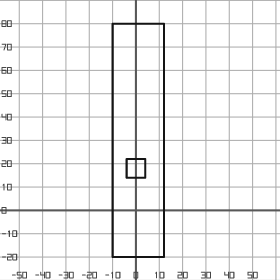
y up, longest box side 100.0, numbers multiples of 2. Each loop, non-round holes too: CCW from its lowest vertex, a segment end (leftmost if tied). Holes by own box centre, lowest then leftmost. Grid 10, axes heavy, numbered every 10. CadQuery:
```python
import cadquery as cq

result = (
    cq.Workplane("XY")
    .moveTo(-10.0, -20.0)
    .lineTo(12.0, -20.0)
    .lineTo(12.0, 80.0)
    .lineTo(-10.0, 80.0)
    .close()
    .moveTo(-4.0, 14.0)
    .lineTo(4.0, 14.0)
    .lineTo(4.0, 22.0)
    .lineTo(-4.0, 22.0)
    .close()
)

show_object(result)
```